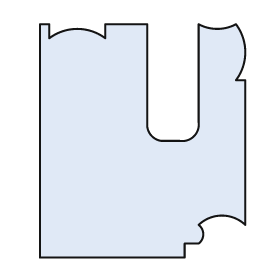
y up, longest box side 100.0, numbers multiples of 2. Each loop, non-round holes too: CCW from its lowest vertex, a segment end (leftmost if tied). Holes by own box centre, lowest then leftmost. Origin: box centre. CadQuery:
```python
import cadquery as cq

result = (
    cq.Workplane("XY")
    .moveTo(-44.0, -50.0)
    .lineTo(18.0, -50.0)
    .lineTo(18.0, -44.0)
    .lineTo(24.0, -44.0)
    .threePointArc((26.0, -40.0), (24.0, -36.0))
    .threePointArc((34.0, -32.0), (44.0, -36.0))
    .lineTo(44.0, 26.0)
    .lineTo(40.0, 26.0)
    .threePointArc((44.0, 38.0), (40.0, 50.0))
    .threePointArc((32.0, 48.0), (24.0, 50.0))
    .lineTo(24.0, 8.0)
    .threePointArc((22.0, 2.0), (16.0, 0.0))
    .lineTo(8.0, 0.0)
    .threePointArc((4.0, 2.0), (2.0, 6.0))
    .lineTo(2.0, 50.0)
    .lineTo(-16.0, 50.0)
    .lineTo(-16.0, 44.0)
    .threePointArc((-28.0, 48.0), (-40.0, 44.0))
    .lineTo(-40.0, 50.0)
    .lineTo(-44.0, 50.0)
    .close()
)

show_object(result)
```